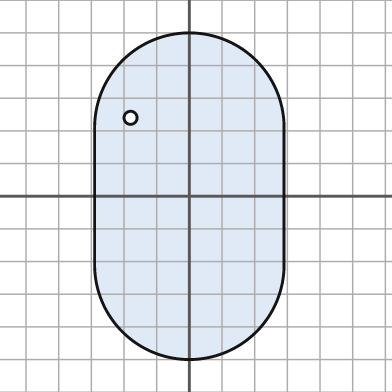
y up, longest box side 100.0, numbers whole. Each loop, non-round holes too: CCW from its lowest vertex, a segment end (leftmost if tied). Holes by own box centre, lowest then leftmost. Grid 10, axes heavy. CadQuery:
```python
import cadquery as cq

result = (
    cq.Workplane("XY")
    .moveTo(-29.0, -21.0)
    .threePointArc((0.0, -50.0), (29.0, -21.0))
    .lineTo(29.0, 21.0)
    .threePointArc((0.0, 50.0), (-29.0, 21.0))
    .close()
    .moveTo(-18.0, 24.0)
    .circle(2.0)
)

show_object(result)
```